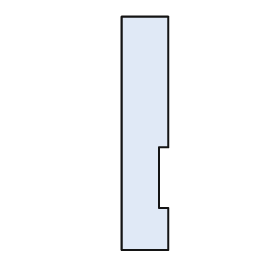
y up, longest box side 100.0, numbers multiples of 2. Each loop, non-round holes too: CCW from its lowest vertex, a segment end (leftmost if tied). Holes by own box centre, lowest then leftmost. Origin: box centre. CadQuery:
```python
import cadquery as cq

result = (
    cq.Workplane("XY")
    .moveTo(-10.0, -50.0)
    .lineTo(10.0, -50.0)
    .lineTo(10.0, -32.0)
    .lineTo(6.0, -32.0)
    .lineTo(6.0, -6.0)
    .lineTo(10.0, -6.0)
    .lineTo(10.0, 50.0)
    .lineTo(-10.0, 50.0)
    .close()
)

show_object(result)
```